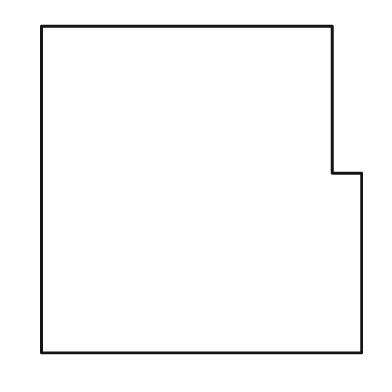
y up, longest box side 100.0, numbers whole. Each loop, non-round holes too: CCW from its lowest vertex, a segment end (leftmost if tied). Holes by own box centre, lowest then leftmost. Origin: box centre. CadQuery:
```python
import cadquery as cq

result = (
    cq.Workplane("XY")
    .moveTo(-49.0, -50.0)
    .lineTo(49.0, -50.0)
    .lineTo(49.0, 5.0)
    .lineTo(40.0, 5.0)
    .lineTo(40.0, 50.0)
    .lineTo(-49.0, 50.0)
    .close()
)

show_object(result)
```